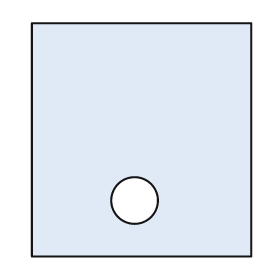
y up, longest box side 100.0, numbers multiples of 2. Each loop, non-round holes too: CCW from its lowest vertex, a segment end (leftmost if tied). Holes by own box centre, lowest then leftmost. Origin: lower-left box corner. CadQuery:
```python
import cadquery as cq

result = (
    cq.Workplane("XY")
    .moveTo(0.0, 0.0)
    .lineTo(94.0, 0.0)
    .lineTo(94.0, 100.0)
    .lineTo(0.0, 100.0)
    .close()
    .moveTo(44.0, 24.0)
    .circle(10.0)
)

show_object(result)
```